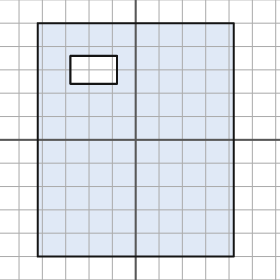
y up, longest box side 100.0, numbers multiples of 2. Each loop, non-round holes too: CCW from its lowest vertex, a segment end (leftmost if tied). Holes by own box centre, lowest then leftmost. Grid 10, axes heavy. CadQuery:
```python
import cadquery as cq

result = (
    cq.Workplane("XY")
    .moveTo(-42.0, -50.0)
    .lineTo(42.0, -50.0)
    .lineTo(42.0, 50.0)
    .lineTo(-42.0, 50.0)
    .close()
    .moveTo(-28.0, 24.0)
    .lineTo(-8.0, 24.0)
    .lineTo(-8.0, 36.0)
    .lineTo(-28.0, 36.0)
    .close()
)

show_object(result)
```